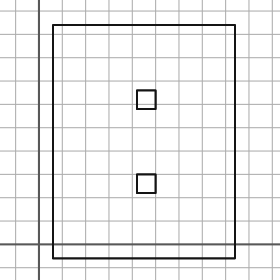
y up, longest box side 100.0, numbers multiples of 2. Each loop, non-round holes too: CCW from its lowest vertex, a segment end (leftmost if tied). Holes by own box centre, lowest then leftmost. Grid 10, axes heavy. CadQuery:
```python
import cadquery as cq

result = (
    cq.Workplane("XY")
    .moveTo(6.0, -6.0)
    .lineTo(84.0, -6.0)
    .lineTo(84.0, 94.0)
    .lineTo(6.0, 94.0)
    .close()
    .moveTo(42.0, 22.0)
    .lineTo(50.0, 22.0)
    .lineTo(50.0, 30.0)
    .lineTo(42.0, 30.0)
    .close()
    .moveTo(42.0, 58.0)
    .lineTo(50.0, 58.0)
    .lineTo(50.0, 66.0)
    .lineTo(42.0, 66.0)
    .close()
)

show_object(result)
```